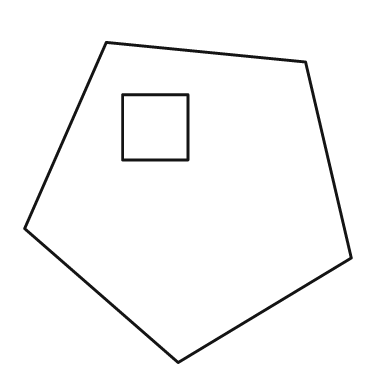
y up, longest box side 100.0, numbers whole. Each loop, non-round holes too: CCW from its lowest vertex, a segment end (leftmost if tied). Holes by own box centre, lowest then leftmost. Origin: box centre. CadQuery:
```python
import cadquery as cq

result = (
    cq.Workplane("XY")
    .moveTo(-3.0, -49.0)
    .lineTo(50.0, -17.0)
    .lineTo(36.0, 43.0)
    .lineTo(-25.0, 49.0)
    .lineTo(-50.0, -8.0)
    .close()
    .moveTo(-20.0, 13.0)
    .lineTo(0.0, 13.0)
    .lineTo(0.0, 33.0)
    .lineTo(-20.0, 33.0)
    .close()
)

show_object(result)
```